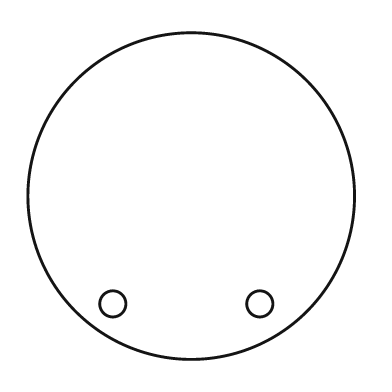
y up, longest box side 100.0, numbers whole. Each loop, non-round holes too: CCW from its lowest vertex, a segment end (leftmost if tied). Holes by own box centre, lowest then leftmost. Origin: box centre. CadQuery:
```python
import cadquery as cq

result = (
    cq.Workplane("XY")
    .moveTo(0.0, 0.0)
    .circle(50.0)
    .moveTo(-24.0, -33.0)
    .circle(4.0)
    .moveTo(21.0, -33.0)
    .circle(4.0)
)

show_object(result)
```